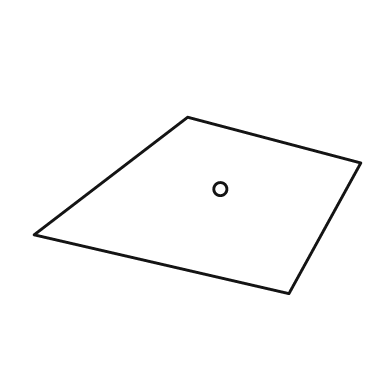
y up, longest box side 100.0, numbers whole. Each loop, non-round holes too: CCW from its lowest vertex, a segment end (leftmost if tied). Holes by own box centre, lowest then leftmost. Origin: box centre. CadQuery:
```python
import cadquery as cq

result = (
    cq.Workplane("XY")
    .moveTo(28.0, -27.0)
    .lineTo(50.0, 13.0)
    .lineTo(-3.0, 27.0)
    .lineTo(-50.0, -9.0)
    .close()
    .moveTo(7.0, 5.0)
    .circle(2.0)
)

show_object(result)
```